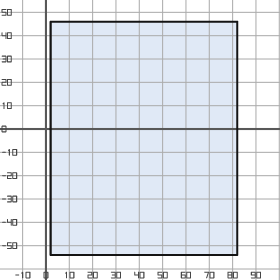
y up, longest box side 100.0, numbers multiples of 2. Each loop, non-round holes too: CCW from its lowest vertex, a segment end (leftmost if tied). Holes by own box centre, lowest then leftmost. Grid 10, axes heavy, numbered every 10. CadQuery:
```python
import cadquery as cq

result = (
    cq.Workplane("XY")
    .moveTo(2.0, -54.0)
    .lineTo(82.0, -54.0)
    .lineTo(82.0, 46.0)
    .lineTo(2.0, 46.0)
    .close()
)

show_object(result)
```